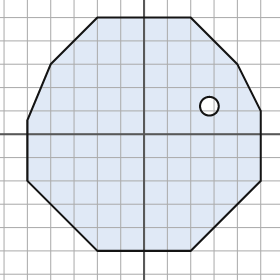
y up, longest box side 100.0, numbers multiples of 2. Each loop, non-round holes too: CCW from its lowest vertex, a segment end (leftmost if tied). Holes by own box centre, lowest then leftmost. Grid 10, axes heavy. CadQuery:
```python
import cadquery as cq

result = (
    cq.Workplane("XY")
    .moveTo(-20.0, -50.0)
    .lineTo(20.0, -50.0)
    .lineTo(50.0, -20.0)
    .lineTo(50.0, 10.0)
    .lineTo(40.0, 30.0)
    .lineTo(20.0, 50.0)
    .lineTo(-20.0, 50.0)
    .lineTo(-40.0, 30.0)
    .lineTo(-50.0, 6.0)
    .lineTo(-50.0, -20.0)
    .close()
    .moveTo(28.0, 12.0)
    .circle(4.0)
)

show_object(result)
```